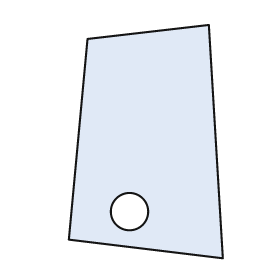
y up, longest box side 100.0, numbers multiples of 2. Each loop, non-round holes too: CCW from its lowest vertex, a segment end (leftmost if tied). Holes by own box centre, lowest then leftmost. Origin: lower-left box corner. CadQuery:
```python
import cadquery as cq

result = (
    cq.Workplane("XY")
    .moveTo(66.0, 0.0)
    .lineTo(60.0, 100.0)
    .lineTo(8.0, 94.0)
    .lineTo(0.0, 8.0)
    .close()
    .moveTo(26.0, 20.0)
    .circle(8.0)
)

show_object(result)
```